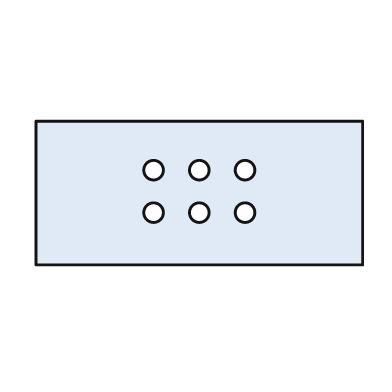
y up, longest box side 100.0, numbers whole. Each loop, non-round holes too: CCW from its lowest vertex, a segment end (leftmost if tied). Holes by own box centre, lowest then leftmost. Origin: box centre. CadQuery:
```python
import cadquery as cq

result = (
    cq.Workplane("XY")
    .moveTo(-50.0, -22.0)
    .lineTo(50.0, -22.0)
    .lineTo(50.0, 22.0)
    .lineTo(-50.0, 22.0)
    .close()
    .moveTo(-14.0, -6.0)
    .circle(3.0)
    .moveTo(0.0, -6.0)
    .circle(3.0)
    .moveTo(14.0, -6.0)
    .circle(3.0)
    .moveTo(-14.0, 7.0)
    .circle(3.0)
    .moveTo(0.0, 7.0)
    .circle(3.0)
    .moveTo(14.0, 7.0)
    .circle(3.0)
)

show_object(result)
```